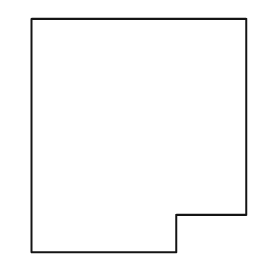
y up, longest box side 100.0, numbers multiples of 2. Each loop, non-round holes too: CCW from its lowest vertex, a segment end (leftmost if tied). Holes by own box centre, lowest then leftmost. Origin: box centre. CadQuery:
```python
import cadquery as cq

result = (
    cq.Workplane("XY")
    .moveTo(-46.0, -50.0)
    .lineTo(16.0, -50.0)
    .lineTo(16.0, -34.0)
    .lineTo(46.0, -34.0)
    .lineTo(46.0, 50.0)
    .lineTo(-46.0, 50.0)
    .close()
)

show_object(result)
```